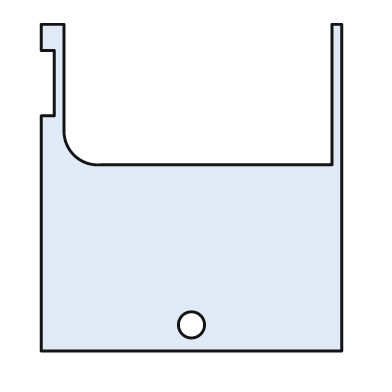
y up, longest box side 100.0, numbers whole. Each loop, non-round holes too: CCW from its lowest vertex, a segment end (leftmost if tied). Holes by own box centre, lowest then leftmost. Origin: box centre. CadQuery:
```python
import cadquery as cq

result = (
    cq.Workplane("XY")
    .moveTo(-46.0, -50.0)
    .lineTo(46.0, -50.0)
    .lineTo(46.0, 50.0)
    .lineTo(43.0, 50.0)
    .lineTo(43.0, 7.0)
    .lineTo(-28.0, 7.0)
    .threePointArc((-36.0, 10.0), (-39.0, 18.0))
    .lineTo(-39.0, 50.0)
    .lineTo(-46.0, 50.0)
    .lineTo(-46.0, 42.0)
    .lineTo(-42.0, 42.0)
    .lineTo(-42.0, 22.0)
    .lineTo(-46.0, 22.0)
    .close()
    .moveTo(0.0, -42.0)
    .circle(4.0)
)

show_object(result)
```